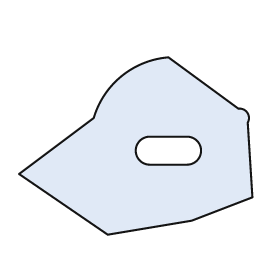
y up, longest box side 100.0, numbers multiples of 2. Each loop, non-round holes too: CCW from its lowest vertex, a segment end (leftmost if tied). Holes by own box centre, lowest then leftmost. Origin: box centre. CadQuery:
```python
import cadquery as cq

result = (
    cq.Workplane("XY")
    .moveTo(-12.0, -38.0)
    .lineTo(24.0, -32.0)
    .lineTo(50.0, -22.0)
    .lineTo(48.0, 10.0)
    .threePointArc((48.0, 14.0), (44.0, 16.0))
    .lineTo(14.0, 38.0)
    .threePointArc((-6.0, 30.0), (-18.0, 12.0))
    .lineTo(-50.0, -12.0)
    .close()
    .moveTo(6.0, -8.0)
    .lineTo(22.0, -8.0)
    .threePointArc((28.0, -2.0), (22.0, 4.0))
    .lineTo(6.0, 4.0)
    .threePointArc((0.0, -2.0), (6.0, -8.0))
    .close()
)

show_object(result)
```